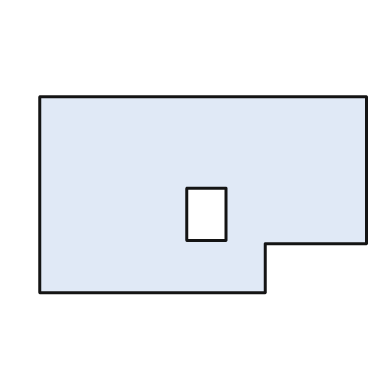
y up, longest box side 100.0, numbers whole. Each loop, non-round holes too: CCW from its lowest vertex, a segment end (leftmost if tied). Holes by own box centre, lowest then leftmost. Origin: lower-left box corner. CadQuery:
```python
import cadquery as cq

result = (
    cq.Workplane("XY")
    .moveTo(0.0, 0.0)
    .lineTo(69.0, 0.0)
    .lineTo(69.0, 15.0)
    .lineTo(100.0, 15.0)
    .lineTo(100.0, 60.0)
    .lineTo(0.0, 60.0)
    .close()
    .moveTo(45.0, 16.0)
    .lineTo(57.0, 16.0)
    .lineTo(57.0, 32.0)
    .lineTo(45.0, 32.0)
    .close()
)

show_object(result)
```